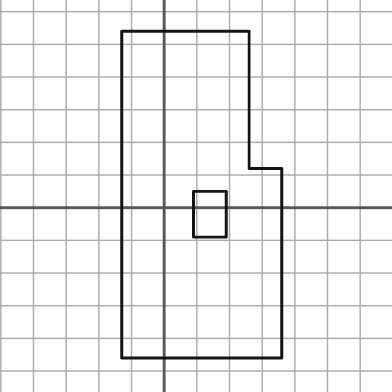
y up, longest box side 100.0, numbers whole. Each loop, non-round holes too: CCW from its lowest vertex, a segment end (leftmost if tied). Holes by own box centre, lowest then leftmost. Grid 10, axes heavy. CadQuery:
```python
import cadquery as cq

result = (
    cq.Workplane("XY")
    .moveTo(-13.0, -46.0)
    .lineTo(36.0, -46.0)
    .lineTo(36.0, 12.0)
    .lineTo(26.0, 12.0)
    .lineTo(26.0, 54.0)
    .lineTo(-13.0, 54.0)
    .close()
    .moveTo(9.0, -9.0)
    .lineTo(19.0, -9.0)
    .lineTo(19.0, 5.0)
    .lineTo(9.0, 5.0)
    .close()
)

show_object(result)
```